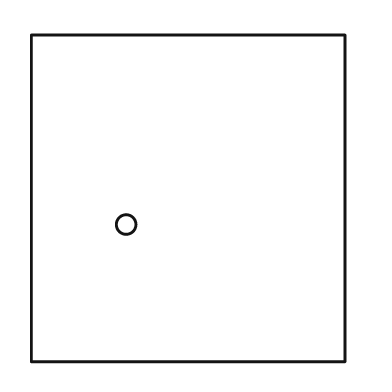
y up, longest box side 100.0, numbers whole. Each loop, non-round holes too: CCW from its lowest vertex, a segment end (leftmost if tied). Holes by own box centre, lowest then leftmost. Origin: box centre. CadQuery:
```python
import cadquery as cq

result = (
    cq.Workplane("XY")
    .moveTo(-48.0, -50.0)
    .lineTo(48.0, -50.0)
    .lineTo(48.0, 50.0)
    .lineTo(-48.0, 50.0)
    .close()
    .moveTo(-19.0, -8.0)
    .circle(3.0)
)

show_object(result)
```